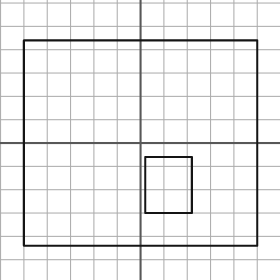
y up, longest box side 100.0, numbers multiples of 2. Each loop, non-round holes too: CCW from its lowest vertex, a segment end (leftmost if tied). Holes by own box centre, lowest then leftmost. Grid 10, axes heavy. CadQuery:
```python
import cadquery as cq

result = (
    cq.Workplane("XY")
    .moveTo(-50.0, -44.0)
    .lineTo(50.0, -44.0)
    .lineTo(50.0, 44.0)
    .lineTo(-50.0, 44.0)
    .close()
    .moveTo(2.0, -30.0)
    .lineTo(22.0, -30.0)
    .lineTo(22.0, -6.0)
    .lineTo(2.0, -6.0)
    .close()
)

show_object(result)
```